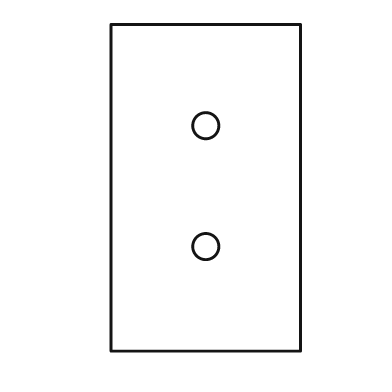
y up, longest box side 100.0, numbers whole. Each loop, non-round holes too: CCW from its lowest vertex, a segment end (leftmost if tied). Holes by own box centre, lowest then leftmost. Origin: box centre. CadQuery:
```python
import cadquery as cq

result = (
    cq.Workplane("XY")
    .moveTo(-29.0, -50.0)
    .lineTo(29.0, -50.0)
    .lineTo(29.0, 50.0)
    .lineTo(-29.0, 50.0)
    .close()
    .moveTo(0.0, -18.0)
    .circle(4.0)
    .moveTo(0.0, 19.0)
    .circle(4.0)
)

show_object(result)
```